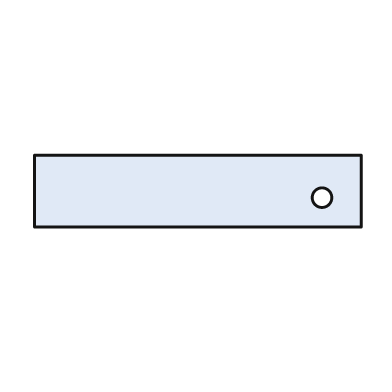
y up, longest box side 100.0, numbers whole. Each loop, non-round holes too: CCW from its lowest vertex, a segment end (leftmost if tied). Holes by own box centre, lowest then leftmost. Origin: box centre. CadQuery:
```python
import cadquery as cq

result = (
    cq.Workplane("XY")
    .moveTo(-50.0, -11.0)
    .lineTo(50.0, -11.0)
    .lineTo(50.0, 11.0)
    .lineTo(-50.0, 11.0)
    .close()
    .moveTo(38.0, -2.0)
    .circle(3.0)
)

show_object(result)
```